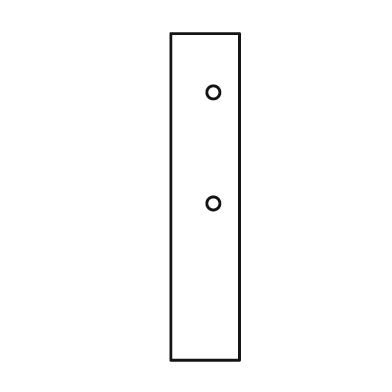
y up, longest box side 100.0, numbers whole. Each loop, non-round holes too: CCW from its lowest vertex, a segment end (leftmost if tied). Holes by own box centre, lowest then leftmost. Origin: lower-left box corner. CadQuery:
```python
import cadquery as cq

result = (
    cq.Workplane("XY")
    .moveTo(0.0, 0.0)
    .lineTo(21.0, 0.0)
    .lineTo(21.0, 100.0)
    .lineTo(0.0, 100.0)
    .close()
    .moveTo(13.0, 48.0)
    .circle(2.0)
    .moveTo(13.0, 82.0)
    .circle(2.0)
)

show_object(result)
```